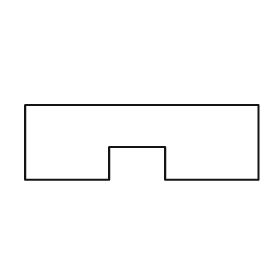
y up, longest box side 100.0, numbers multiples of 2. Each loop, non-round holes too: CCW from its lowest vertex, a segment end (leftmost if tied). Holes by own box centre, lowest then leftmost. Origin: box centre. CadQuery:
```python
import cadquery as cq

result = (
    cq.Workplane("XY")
    .moveTo(-50.0, -16.0)
    .lineTo(-14.0, -16.0)
    .lineTo(-14.0, -2.0)
    .lineTo(10.0, -2.0)
    .lineTo(10.0, -16.0)
    .lineTo(50.0, -16.0)
    .lineTo(50.0, 16.0)
    .lineTo(-50.0, 16.0)
    .close()
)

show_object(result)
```